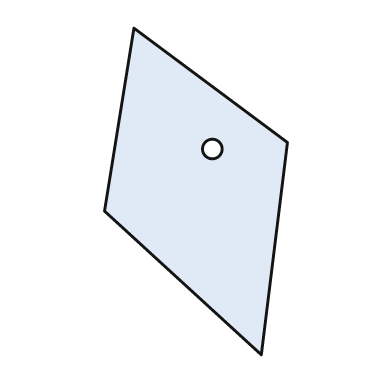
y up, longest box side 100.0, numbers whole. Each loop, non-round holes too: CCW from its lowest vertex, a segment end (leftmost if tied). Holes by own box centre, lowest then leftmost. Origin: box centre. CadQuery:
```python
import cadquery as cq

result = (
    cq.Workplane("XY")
    .moveTo(20.0, -50.0)
    .lineTo(28.0, 15.0)
    .lineTo(-19.0, 50.0)
    .lineTo(-28.0, -6.0)
    .close()
    .moveTo(5.0, 13.0)
    .circle(3.0)
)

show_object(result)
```